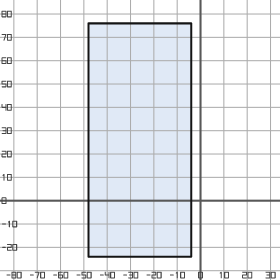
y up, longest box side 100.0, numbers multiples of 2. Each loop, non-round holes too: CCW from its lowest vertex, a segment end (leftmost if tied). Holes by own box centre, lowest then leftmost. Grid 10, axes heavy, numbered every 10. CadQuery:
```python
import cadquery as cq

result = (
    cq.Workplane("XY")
    .moveTo(-48.0, -24.0)
    .lineTo(-4.0, -24.0)
    .lineTo(-4.0, 76.0)
    .lineTo(-48.0, 76.0)
    .close()
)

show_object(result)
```